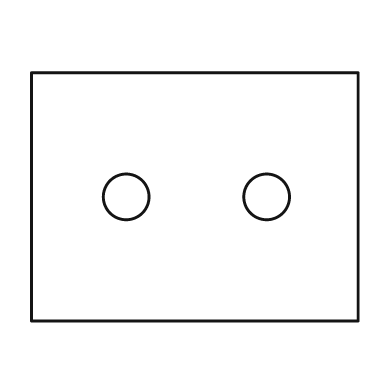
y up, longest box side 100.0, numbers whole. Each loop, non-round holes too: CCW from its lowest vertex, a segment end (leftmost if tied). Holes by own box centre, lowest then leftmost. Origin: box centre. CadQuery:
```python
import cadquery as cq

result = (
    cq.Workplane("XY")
    .moveTo(-50.0, -38.0)
    .lineTo(50.0, -38.0)
    .lineTo(50.0, 38.0)
    .lineTo(-50.0, 38.0)
    .close()
    .moveTo(-21.0, 0.0)
    .circle(7.0)
    .moveTo(22.0, 0.0)
    .circle(7.0)
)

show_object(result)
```